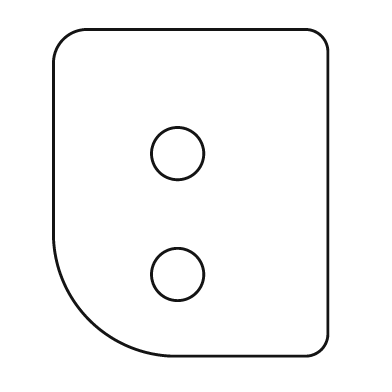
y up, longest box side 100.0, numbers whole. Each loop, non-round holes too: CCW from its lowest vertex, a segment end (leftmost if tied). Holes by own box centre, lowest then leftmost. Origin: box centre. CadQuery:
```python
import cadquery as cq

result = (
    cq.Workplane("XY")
    .moveTo(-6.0, -50.0)
    .lineTo(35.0, -50.0)
    .threePointArc((40.0, -48.0), (42.0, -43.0))
    .lineTo(42.0, 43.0)
    .threePointArc((40.0, 48.0), (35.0, 50.0))
    .lineTo(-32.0, 50.0)
    .threePointArc((-39.0, 47.0), (-42.0, 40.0))
    .lineTo(-42.0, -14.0)
    .threePointArc((-31.0, -39.0), (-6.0, -50.0))
    .close()
    .moveTo(-4.0, -25.0)
    .circle(8.0)
    .moveTo(-4.0, 12.0)
    .circle(8.0)
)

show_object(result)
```